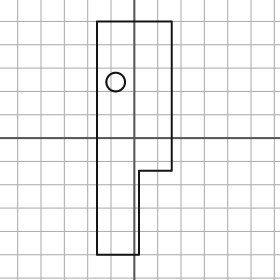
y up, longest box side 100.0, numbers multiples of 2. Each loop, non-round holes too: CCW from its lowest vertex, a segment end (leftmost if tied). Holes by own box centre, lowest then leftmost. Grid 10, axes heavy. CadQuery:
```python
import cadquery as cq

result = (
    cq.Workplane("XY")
    .moveTo(-16.0, -50.0)
    .lineTo(2.0, -50.0)
    .lineTo(2.0, -14.0)
    .lineTo(16.0, -14.0)
    .lineTo(16.0, 50.0)
    .lineTo(-16.0, 50.0)
    .close()
    .moveTo(-8.0, 24.0)
    .circle(4.0)
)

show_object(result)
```